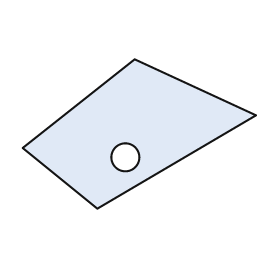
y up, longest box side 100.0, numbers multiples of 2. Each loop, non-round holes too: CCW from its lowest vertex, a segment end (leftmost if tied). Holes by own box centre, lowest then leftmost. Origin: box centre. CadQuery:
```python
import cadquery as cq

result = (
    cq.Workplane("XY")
    .moveTo(-18.0, -32.0)
    .lineTo(50.0, 8.0)
    .lineTo(-2.0, 32.0)
    .lineTo(-50.0, -6.0)
    .close()
    .moveTo(-6.0, -10.0)
    .circle(6.0)
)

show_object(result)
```